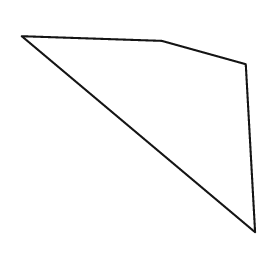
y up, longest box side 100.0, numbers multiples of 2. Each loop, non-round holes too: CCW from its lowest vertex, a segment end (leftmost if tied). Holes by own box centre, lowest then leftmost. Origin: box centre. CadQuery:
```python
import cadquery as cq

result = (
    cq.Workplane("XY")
    .moveTo(50.0, -42.0)
    .lineTo(46.0, 30.0)
    .lineTo(10.0, 40.0)
    .lineTo(-50.0, 42.0)
    .close()
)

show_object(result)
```